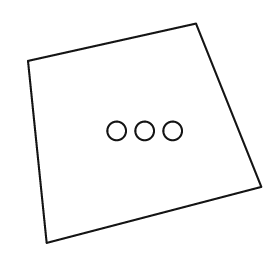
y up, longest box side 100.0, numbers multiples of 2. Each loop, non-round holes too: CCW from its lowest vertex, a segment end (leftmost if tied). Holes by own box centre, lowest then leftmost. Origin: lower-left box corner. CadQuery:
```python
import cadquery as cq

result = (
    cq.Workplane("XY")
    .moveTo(8.0, 0.0)
    .lineTo(100.0, 24.0)
    .lineTo(72.0, 94.0)
    .lineTo(0.0, 78.0)
    .close()
    .moveTo(38.0, 48.0)
    .circle(4.0)
    .moveTo(50.0, 48.0)
    .circle(4.0)
    .moveTo(62.0, 48.0)
    .circle(4.0)
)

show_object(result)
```